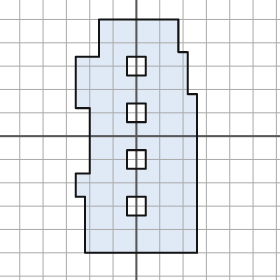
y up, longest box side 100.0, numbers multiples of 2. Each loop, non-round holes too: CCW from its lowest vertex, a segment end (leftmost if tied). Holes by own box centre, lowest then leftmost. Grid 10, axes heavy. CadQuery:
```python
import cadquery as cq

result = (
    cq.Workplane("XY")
    .moveTo(-22.0, -50.0)
    .lineTo(26.0, -50.0)
    .lineTo(26.0, 18.0)
    .lineTo(22.0, 18.0)
    .lineTo(22.0, 36.0)
    .lineTo(18.0, 36.0)
    .lineTo(18.0, 50.0)
    .lineTo(-16.0, 50.0)
    .lineTo(-16.0, 34.0)
    .lineTo(-26.0, 34.0)
    .lineTo(-26.0, 12.0)
    .lineTo(-20.0, 12.0)
    .lineTo(-20.0, -16.0)
    .lineTo(-26.0, -16.0)
    .lineTo(-26.0, -26.0)
    .lineTo(-22.0, -26.0)
    .close()
    .moveTo(-4.0, -34.0)
    .lineTo(4.0, -34.0)
    .lineTo(4.0, -26.0)
    .lineTo(-4.0, -26.0)
    .close()
    .moveTo(-4.0, -14.0)
    .lineTo(4.0, -14.0)
    .lineTo(4.0, -6.0)
    .lineTo(-4.0, -6.0)
    .close()
    .moveTo(-4.0, 6.0)
    .lineTo(4.0, 6.0)
    .lineTo(4.0, 14.0)
    .lineTo(-4.0, 14.0)
    .close()
    .moveTo(-4.0, 26.0)
    .lineTo(4.0, 26.0)
    .lineTo(4.0, 34.0)
    .lineTo(-4.0, 34.0)
    .close()
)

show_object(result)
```